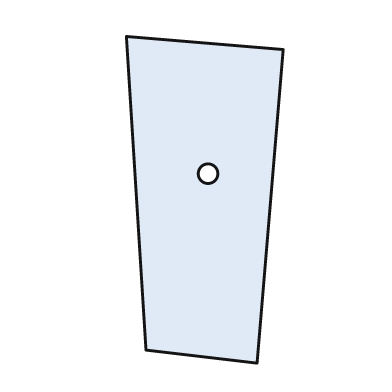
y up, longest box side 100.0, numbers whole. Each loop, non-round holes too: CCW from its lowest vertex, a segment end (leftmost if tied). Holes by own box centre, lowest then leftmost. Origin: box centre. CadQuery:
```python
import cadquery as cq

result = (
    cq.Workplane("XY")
    .moveTo(16.0, -50.0)
    .lineTo(24.0, 46.0)
    .lineTo(-24.0, 50.0)
    .lineTo(-18.0, -46.0)
    .close()
    .moveTo(1.0, 8.0)
    .circle(3.0)
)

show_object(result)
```